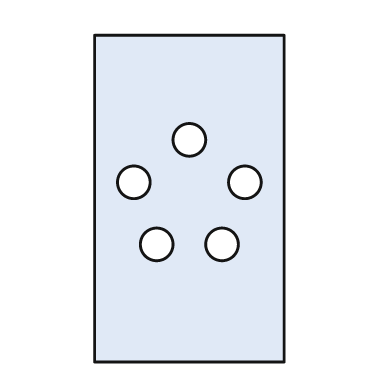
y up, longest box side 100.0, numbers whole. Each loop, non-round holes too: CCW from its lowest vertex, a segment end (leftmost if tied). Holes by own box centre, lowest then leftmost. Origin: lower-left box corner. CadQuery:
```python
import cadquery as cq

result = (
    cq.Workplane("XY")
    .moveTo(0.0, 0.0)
    .lineTo(58.0, 0.0)
    .lineTo(58.0, 100.0)
    .lineTo(0.0, 100.0)
    .close()
    .moveTo(19.0, 36.0)
    .circle(5.0)
    .moveTo(39.0, 36.0)
    .circle(5.0)
    .moveTo(12.0, 55.0)
    .circle(5.0)
    .moveTo(46.0, 55.0)
    .circle(5.0)
    .moveTo(29.0, 68.0)
    .circle(5.0)
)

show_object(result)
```